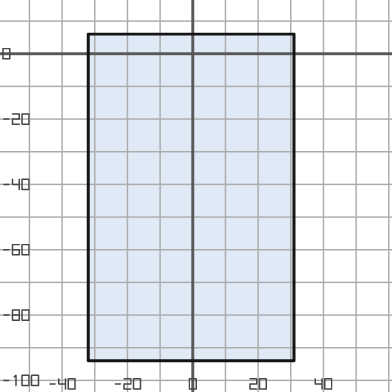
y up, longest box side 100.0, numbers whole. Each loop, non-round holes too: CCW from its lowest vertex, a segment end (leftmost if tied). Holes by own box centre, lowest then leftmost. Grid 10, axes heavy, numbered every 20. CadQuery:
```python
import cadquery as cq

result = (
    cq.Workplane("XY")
    .moveTo(-32.0, -94.0)
    .lineTo(31.0, -94.0)
    .lineTo(31.0, 6.0)
    .lineTo(-32.0, 6.0)
    .close()
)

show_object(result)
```